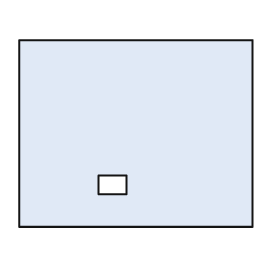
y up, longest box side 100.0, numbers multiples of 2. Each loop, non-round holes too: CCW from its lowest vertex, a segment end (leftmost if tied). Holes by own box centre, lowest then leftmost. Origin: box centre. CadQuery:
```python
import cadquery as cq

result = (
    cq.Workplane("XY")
    .moveTo(-50.0, -40.0)
    .lineTo(50.0, -40.0)
    .lineTo(50.0, 40.0)
    .lineTo(-50.0, 40.0)
    .close()
    .moveTo(-16.0, -26.0)
    .lineTo(-4.0, -26.0)
    .lineTo(-4.0, -18.0)
    .lineTo(-16.0, -18.0)
    .close()
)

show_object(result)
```